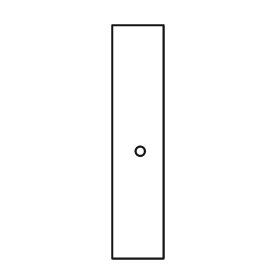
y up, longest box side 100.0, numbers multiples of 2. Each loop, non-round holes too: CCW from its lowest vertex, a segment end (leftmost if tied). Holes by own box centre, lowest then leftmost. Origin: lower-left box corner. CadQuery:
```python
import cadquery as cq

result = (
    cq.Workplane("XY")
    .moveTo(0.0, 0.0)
    .lineTo(22.0, 0.0)
    .lineTo(22.0, 100.0)
    .lineTo(0.0, 100.0)
    .close()
    .moveTo(12.0, 46.0)
    .circle(2.0)
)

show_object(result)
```